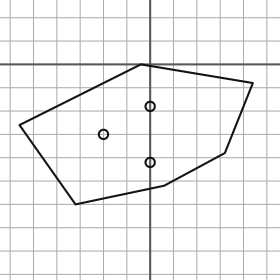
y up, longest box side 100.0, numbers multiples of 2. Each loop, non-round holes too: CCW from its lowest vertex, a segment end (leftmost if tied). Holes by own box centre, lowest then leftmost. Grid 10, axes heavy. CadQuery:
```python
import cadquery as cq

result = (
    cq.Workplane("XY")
    .moveTo(-32.0, -60.0)
    .lineTo(6.0, -52.0)
    .lineTo(32.0, -38.0)
    .lineTo(44.0, -8.0)
    .lineTo(-4.0, 0.0)
    .lineTo(-56.0, -26.0)
    .close()
    .moveTo(0.0, -42.0)
    .circle(2.0)
    .moveTo(-20.0, -30.0)
    .circle(2.0)
    .moveTo(0.0, -18.0)
    .circle(2.0)
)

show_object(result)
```